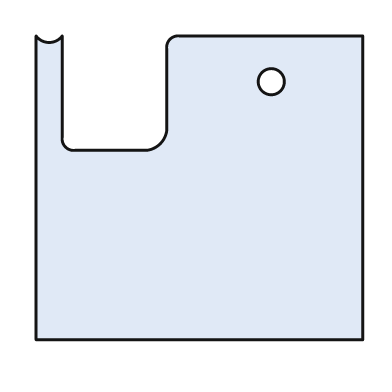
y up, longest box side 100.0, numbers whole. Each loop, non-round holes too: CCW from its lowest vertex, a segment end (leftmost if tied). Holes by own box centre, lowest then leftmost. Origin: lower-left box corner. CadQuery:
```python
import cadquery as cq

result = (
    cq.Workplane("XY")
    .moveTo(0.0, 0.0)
    .lineTo(100.0, 0.0)
    .lineTo(100.0, 93.0)
    .lineTo(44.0, 93.0)
    .threePointArc((41.0, 92.0), (40.0, 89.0))
    .lineTo(40.0, 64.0)
    .threePointArc((38.0, 60.0), (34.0, 58.0))
    .lineTo(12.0, 58.0)
    .threePointArc((9.0, 59.0), (8.0, 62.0))
    .lineTo(8.0, 93.0)
    .threePointArc((4.0, 91.0), (0.0, 93.0))
    .close()
    .moveTo(72.0, 79.0)
    .circle(4.0)
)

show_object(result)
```